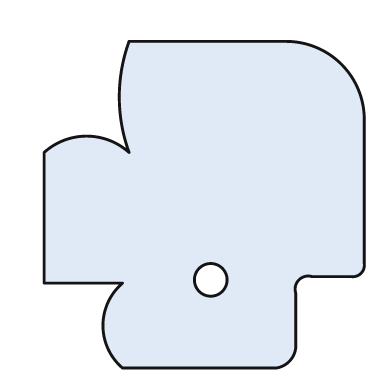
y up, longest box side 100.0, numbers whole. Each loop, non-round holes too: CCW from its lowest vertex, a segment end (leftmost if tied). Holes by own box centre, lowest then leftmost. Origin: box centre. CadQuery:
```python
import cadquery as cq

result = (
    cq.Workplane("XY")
    .moveTo(-25.0, -50.0)
    .lineTo(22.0, -50.0)
    .threePointArc((26.0, -48.0), (28.0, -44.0))
    .lineTo(28.0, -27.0)
    .threePointArc((29.0, -23.0), (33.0, -22.0))
    .lineTo(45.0, -22.0)
    .threePointArc((48.0, -21.0), (49.0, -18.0))
    .lineTo(49.0, 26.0)
    .threePointArc((42.0, 43.0), (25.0, 50.0))
    .lineTo(-23.0, 50.0)
    .threePointArc((-26.0, 33.0), (-23.0, 16.0))
    .threePointArc((-36.0, 21.0), (-49.0, 16.0))
    .lineTo(-49.0, -24.0)
    .lineTo(-25.0, -24.0)
    .threePointArc((-31.0, -37.0), (-25.0, -50.0))
    .close()
    .moveTo(2.0, -23.0)
    .circle(5.0)
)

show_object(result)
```